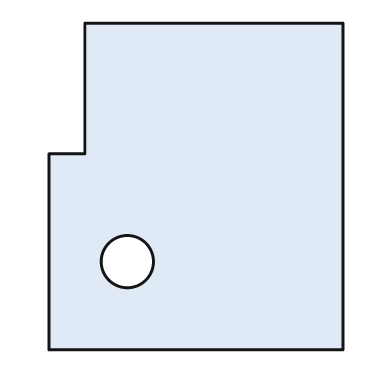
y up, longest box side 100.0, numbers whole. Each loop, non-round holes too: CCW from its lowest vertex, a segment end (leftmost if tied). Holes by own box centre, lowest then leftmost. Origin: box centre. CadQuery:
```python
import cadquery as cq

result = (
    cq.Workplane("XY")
    .moveTo(-45.0, -50.0)
    .lineTo(45.0, -50.0)
    .lineTo(45.0, 50.0)
    .lineTo(-34.0, 50.0)
    .lineTo(-34.0, 10.0)
    .lineTo(-45.0, 10.0)
    .close()
    .moveTo(-21.0, -23.0)
    .circle(8.0)
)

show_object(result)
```